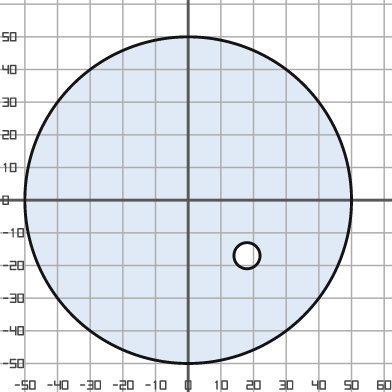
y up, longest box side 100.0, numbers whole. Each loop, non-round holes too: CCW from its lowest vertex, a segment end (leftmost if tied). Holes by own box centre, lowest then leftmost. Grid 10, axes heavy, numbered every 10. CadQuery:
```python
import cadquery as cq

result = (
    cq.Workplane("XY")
    .moveTo(0.0, 0.0)
    .circle(50.0)
    .moveTo(18.0, -17.0)
    .circle(4.0)
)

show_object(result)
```